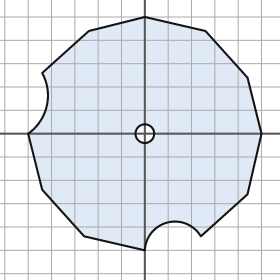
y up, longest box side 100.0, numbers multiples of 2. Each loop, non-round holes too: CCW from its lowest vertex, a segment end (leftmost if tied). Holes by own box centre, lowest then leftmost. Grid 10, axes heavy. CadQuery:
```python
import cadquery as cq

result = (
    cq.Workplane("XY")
    .moveTo(0.0, -50.0)
    .threePointArc((10.0, -38.0), (24.0, -44.0))
    .lineTo(44.0, -26.0)
    .lineTo(50.0, 0.0)
    .lineTo(44.0, 24.0)
    .lineTo(26.0, 44.0)
    .lineTo(0.0, 50.0)
    .lineTo(-24.0, 44.0)
    .lineTo(-44.0, 26.0)
    .threePointArc((-42.0, 12.0), (-50.0, 0.0))
    .lineTo(-44.0, -24.0)
    .lineTo(-26.0, -44.0)
    .close()
    .moveTo(0.0, 0.0)
    .circle(4.0)
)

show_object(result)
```